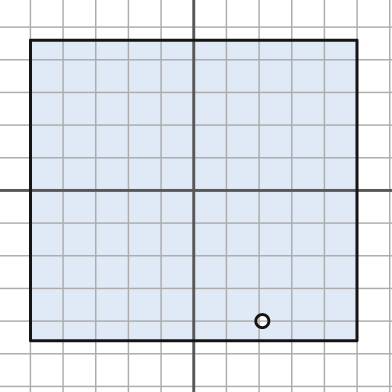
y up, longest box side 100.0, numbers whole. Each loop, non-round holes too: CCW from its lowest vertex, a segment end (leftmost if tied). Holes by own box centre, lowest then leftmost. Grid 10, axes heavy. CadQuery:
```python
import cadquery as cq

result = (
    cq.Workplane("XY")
    .moveTo(-50.0, -46.0)
    .lineTo(50.0, -46.0)
    .lineTo(50.0, 46.0)
    .lineTo(-50.0, 46.0)
    .close()
    .moveTo(21.0, -40.0)
    .circle(2.0)
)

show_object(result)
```